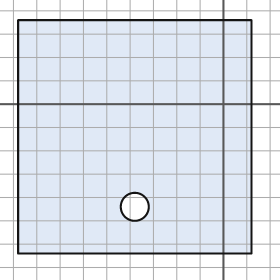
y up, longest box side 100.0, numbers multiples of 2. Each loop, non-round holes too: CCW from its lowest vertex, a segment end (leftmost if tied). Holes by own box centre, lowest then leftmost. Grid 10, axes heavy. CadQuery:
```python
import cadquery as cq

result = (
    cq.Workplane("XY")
    .moveTo(-88.0, -64.0)
    .lineTo(12.0, -64.0)
    .lineTo(12.0, 36.0)
    .lineTo(-88.0, 36.0)
    .close()
    .moveTo(-38.0, -44.0)
    .circle(6.0)
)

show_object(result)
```